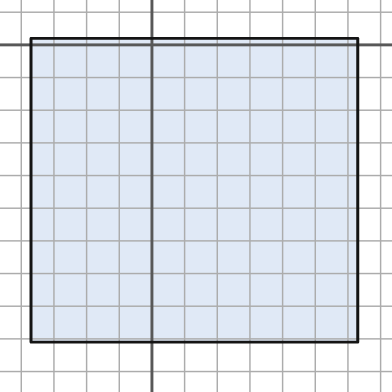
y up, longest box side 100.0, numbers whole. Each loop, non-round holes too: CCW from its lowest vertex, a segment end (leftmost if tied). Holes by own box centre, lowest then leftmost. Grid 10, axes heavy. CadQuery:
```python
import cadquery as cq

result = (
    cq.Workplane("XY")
    .moveTo(-37.0, -91.0)
    .lineTo(63.0, -91.0)
    .lineTo(63.0, 2.0)
    .lineTo(-37.0, 2.0)
    .close()
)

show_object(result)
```